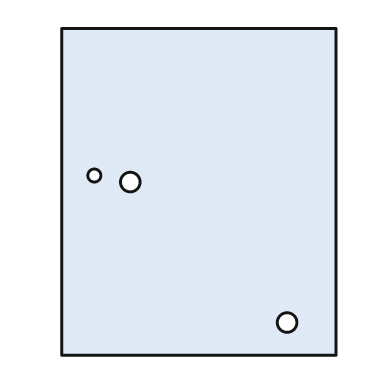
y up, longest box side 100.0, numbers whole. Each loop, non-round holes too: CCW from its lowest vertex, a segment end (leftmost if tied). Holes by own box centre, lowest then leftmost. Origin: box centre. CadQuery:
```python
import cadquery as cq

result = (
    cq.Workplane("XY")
    .moveTo(-42.0, -50.0)
    .lineTo(42.0, -50.0)
    .lineTo(42.0, 50.0)
    .lineTo(-42.0, 50.0)
    .close()
    .moveTo(27.0, -40.0)
    .circle(3.0)
    .moveTo(-21.0, 3.0)
    .circle(3.0)
    .moveTo(-32.0, 5.0)
    .circle(2.0)
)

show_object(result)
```